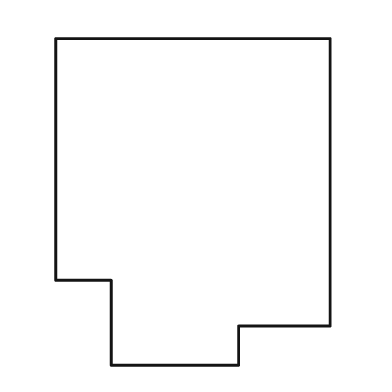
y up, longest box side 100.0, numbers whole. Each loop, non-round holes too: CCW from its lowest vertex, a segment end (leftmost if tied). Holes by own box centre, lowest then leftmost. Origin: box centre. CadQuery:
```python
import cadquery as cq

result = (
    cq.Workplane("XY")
    .moveTo(-25.0, -50.0)
    .lineTo(14.0, -50.0)
    .lineTo(14.0, -38.0)
    .lineTo(42.0, -38.0)
    .lineTo(42.0, 50.0)
    .lineTo(-42.0, 50.0)
    .lineTo(-42.0, -24.0)
    .lineTo(-25.0, -24.0)
    .close()
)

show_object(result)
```